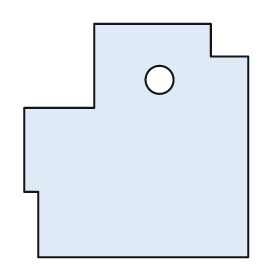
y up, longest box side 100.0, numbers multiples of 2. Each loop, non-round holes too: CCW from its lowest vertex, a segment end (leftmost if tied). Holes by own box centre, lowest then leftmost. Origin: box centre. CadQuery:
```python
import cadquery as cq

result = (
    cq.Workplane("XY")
    .moveTo(-42.0, -50.0)
    .lineTo(48.0, -50.0)
    .lineTo(48.0, 36.0)
    .lineTo(32.0, 36.0)
    .lineTo(32.0, 50.0)
    .lineTo(-18.0, 50.0)
    .lineTo(-18.0, 14.0)
    .lineTo(-48.0, 14.0)
    .lineTo(-48.0, -22.0)
    .lineTo(-42.0, -22.0)
    .close()
    .moveTo(10.0, 26.0)
    .circle(6.0)
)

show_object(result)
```